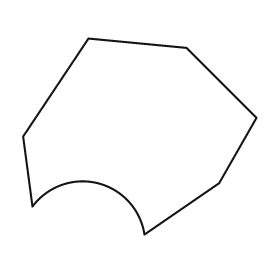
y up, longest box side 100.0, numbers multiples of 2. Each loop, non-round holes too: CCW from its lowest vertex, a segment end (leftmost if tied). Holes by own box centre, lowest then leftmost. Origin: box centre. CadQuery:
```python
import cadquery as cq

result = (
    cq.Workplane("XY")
    .moveTo(2.0, -42.0)
    .lineTo(34.0, -20.0)
    .lineTo(50.0, 8.0)
    .lineTo(20.0, 38.0)
    .lineTo(-22.0, 42.0)
    .lineTo(-50.0, 0.0)
    .lineTo(-46.0, -30.0)
    .threePointArc((-18.0, -20.0), (2.0, -42.0))
    .close()
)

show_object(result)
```